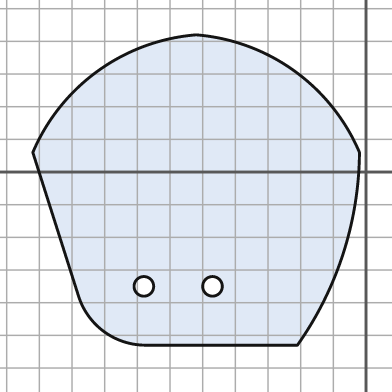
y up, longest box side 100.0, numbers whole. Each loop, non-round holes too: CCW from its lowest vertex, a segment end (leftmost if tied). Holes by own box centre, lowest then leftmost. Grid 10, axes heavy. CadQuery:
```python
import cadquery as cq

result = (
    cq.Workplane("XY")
    .moveTo(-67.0, -53.0)
    .lineTo(-21.0, -53.0)
    .threePointArc((-7.0, -25.0), (-2.0, 6.0))
    .threePointArc((-22.0, 31.0), (-52.0, 42.0))
    .threePointArc((-82.0, 31.0), (-102.0, 6.0))
    .lineTo(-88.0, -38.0)
    .threePointArc((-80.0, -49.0), (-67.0, -53.0))
    .close()
    .moveTo(-68.0, -35.0)
    .circle(3.0)
    .moveTo(-47.0, -35.0)
    .circle(3.0)
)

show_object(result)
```